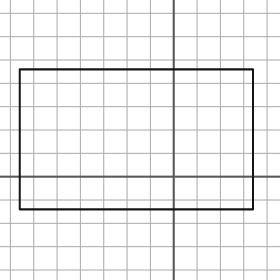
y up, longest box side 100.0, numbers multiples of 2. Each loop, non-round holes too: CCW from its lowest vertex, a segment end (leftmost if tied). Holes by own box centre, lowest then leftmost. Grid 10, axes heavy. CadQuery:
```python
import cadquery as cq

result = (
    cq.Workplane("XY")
    .moveTo(-66.0, -14.0)
    .lineTo(34.0, -14.0)
    .lineTo(34.0, 46.0)
    .lineTo(-66.0, 46.0)
    .close()
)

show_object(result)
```